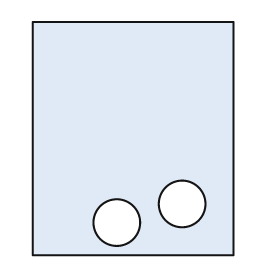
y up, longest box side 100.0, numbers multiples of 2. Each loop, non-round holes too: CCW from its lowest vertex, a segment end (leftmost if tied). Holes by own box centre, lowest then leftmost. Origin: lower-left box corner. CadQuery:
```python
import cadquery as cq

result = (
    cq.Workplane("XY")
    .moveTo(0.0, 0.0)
    .lineTo(86.0, 0.0)
    .lineTo(86.0, 100.0)
    .lineTo(0.0, 100.0)
    .close()
    .moveTo(36.0, 14.0)
    .circle(10.0)
    .moveTo(64.0, 22.0)
    .circle(10.0)
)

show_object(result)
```